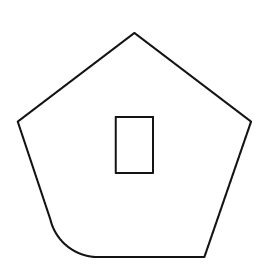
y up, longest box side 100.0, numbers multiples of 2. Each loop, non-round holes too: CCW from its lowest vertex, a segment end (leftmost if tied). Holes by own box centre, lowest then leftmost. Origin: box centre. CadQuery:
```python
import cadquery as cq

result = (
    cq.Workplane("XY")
    .moveTo(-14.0, -48.0)
    .lineTo(30.0, -48.0)
    .lineTo(50.0, 10.0)
    .lineTo(0.0, 48.0)
    .lineTo(-50.0, 10.0)
    .lineTo(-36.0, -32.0)
    .threePointArc((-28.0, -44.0), (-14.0, -48.0))
    .close()
    .moveTo(-8.0, -12.0)
    .lineTo(8.0, -12.0)
    .lineTo(8.0, 12.0)
    .lineTo(-8.0, 12.0)
    .close()
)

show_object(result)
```